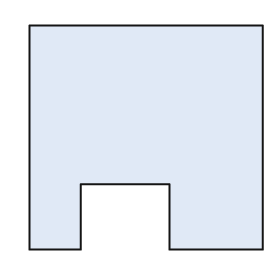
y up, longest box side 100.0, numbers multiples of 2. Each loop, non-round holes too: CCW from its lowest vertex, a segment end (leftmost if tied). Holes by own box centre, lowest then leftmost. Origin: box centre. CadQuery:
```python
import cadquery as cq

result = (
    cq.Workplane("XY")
    .moveTo(-50.0, -48.0)
    .lineTo(-28.0, -48.0)
    .lineTo(-28.0, -20.0)
    .lineTo(10.0, -20.0)
    .lineTo(10.0, -48.0)
    .lineTo(50.0, -48.0)
    .lineTo(50.0, 48.0)
    .lineTo(-50.0, 48.0)
    .close()
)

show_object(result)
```